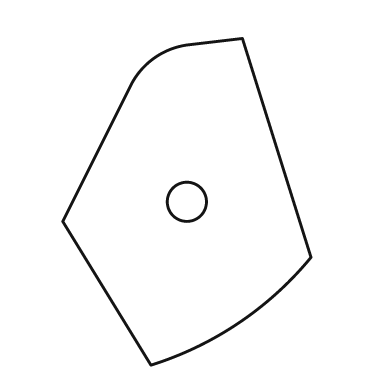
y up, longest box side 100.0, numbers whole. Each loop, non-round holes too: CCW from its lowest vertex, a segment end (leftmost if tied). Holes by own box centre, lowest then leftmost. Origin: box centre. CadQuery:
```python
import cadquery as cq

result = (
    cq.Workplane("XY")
    .moveTo(-11.0, -50.0)
    .threePointArc((16.0, -37.0), (38.0, -17.0))
    .lineTo(17.0, 50.0)
    .lineTo(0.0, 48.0)
    .threePointArc((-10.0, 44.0), (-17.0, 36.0))
    .lineTo(-38.0, -6.0)
    .close()
    .moveTo(0.0, 0.0)
    .circle(6.0)
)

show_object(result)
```